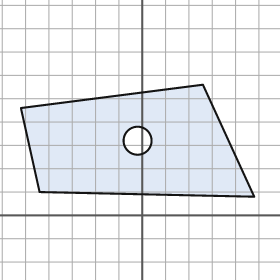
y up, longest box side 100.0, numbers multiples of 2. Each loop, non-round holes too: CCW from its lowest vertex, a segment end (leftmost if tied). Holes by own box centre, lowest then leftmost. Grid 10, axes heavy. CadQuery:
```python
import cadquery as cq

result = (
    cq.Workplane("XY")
    .moveTo(48.0, 8.0)
    .lineTo(26.0, 56.0)
    .lineTo(-52.0, 46.0)
    .lineTo(-44.0, 10.0)
    .close()
    .moveTo(-2.0, 32.0)
    .circle(6.0)
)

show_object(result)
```